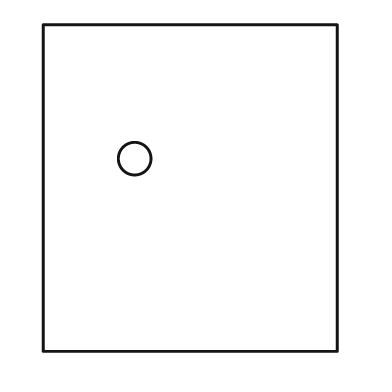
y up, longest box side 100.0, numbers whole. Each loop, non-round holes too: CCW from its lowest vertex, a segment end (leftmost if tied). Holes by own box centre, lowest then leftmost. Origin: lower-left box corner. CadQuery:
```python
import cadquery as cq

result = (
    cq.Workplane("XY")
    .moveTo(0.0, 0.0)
    .lineTo(90.0, 0.0)
    .lineTo(90.0, 100.0)
    .lineTo(0.0, 100.0)
    .close()
    .moveTo(28.0, 59.0)
    .circle(5.0)
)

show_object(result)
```